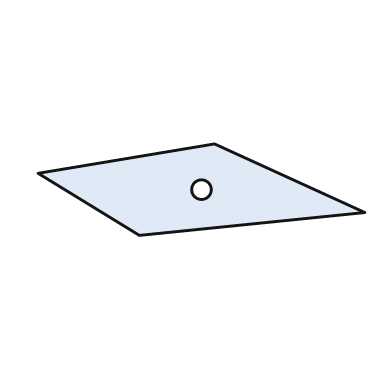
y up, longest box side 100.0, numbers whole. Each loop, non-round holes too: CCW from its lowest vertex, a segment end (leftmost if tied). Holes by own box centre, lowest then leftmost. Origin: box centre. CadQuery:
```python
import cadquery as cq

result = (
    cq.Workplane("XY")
    .moveTo(-19.0, -14.0)
    .lineTo(50.0, -7.0)
    .lineTo(4.0, 14.0)
    .lineTo(-50.0, 5.0)
    .close()
    .moveTo(0.0, 0.0)
    .circle(3.0)
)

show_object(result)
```